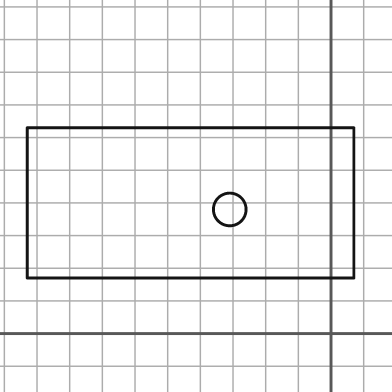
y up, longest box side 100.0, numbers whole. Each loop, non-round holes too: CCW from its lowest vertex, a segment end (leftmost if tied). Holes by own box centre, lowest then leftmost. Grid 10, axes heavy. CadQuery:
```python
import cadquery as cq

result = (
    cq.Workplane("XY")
    .moveTo(-93.0, 17.0)
    .lineTo(7.0, 17.0)
    .lineTo(7.0, 63.0)
    .lineTo(-93.0, 63.0)
    .close()
    .moveTo(-31.0, 38.0)
    .circle(5.0)
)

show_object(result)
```